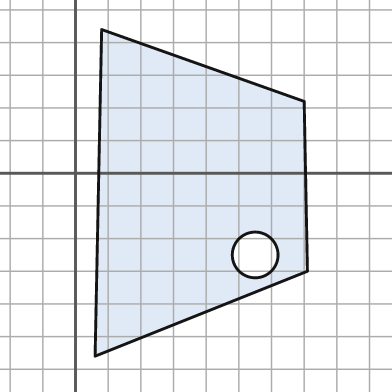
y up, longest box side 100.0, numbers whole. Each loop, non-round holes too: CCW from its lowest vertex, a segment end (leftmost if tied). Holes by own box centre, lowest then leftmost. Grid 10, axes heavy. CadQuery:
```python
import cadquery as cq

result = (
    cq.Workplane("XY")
    .moveTo(6.0, -56.0)
    .lineTo(71.0, -30.0)
    .lineTo(70.0, 22.0)
    .lineTo(8.0, 44.0)
    .close()
    .moveTo(55.0, -25.0)
    .circle(7.0)
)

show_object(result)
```